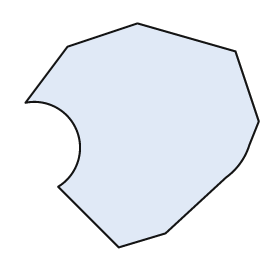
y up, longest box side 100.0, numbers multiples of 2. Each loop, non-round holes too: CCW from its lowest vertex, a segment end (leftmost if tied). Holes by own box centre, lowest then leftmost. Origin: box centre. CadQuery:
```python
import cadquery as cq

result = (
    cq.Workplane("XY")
    .moveTo(-10.0, -48.0)
    .lineTo(10.0, -42.0)
    .lineTo(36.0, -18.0)
    .threePointArc((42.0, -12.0), (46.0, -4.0))
    .lineTo(50.0, 6.0)
    .lineTo(40.0, 36.0)
    .lineTo(-2.0, 48.0)
    .lineTo(-32.0, 38.0)
    .lineTo(-50.0, 14.0)
    .threePointArc((-28.0, 2.0), (-36.0, -22.0))
    .close()
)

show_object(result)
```